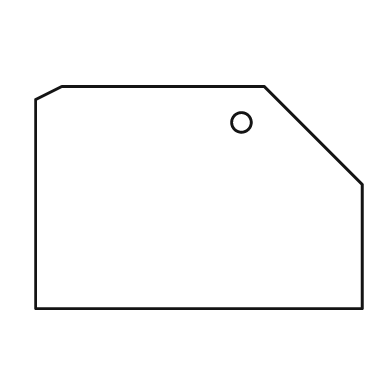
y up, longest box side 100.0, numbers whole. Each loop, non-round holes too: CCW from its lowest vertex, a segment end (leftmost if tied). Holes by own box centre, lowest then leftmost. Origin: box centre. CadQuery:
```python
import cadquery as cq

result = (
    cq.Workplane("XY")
    .moveTo(-50.0, -34.0)
    .lineTo(50.0, -34.0)
    .lineTo(50.0, 4.0)
    .lineTo(20.0, 34.0)
    .lineTo(-42.0, 34.0)
    .lineTo(-50.0, 30.0)
    .close()
    .moveTo(13.0, 23.0)
    .circle(3.0)
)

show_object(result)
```